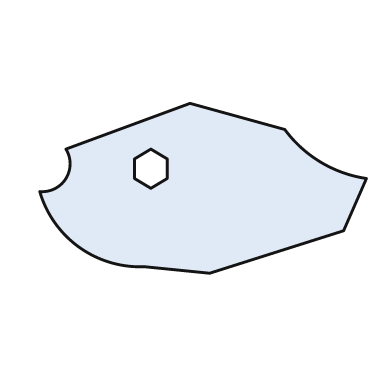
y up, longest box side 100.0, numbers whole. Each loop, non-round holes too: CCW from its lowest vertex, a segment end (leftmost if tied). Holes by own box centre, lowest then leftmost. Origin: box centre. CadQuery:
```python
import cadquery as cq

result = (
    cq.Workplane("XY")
    .moveTo(2.0, -26.0)
    .lineTo(43.0, -13.0)
    .lineTo(50.0, 3.0)
    .threePointArc((36.0, 8.0), (25.0, 18.0))
    .lineTo(-4.0, 26.0)
    .lineTo(-42.0, 12.0)
    .threePointArc((-42.0, 3.0), (-50.0, -1.0))
    .threePointArc((-38.0, -18.0), (-18.0, -24.0))
    .close()
    .moveTo(-16.0, 0.0)
    .lineTo(-11.0, 3.0)
    .lineTo(-11.0, 9.0)
    .lineTo(-16.0, 12.0)
    .lineTo(-21.0, 9.0)
    .lineTo(-21.0, 3.0)
    .close()
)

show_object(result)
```